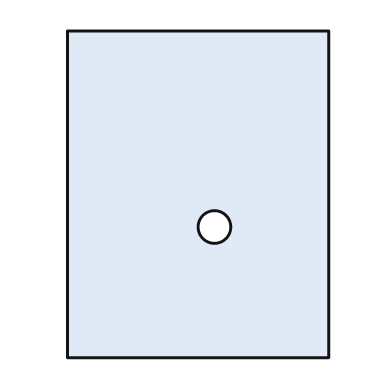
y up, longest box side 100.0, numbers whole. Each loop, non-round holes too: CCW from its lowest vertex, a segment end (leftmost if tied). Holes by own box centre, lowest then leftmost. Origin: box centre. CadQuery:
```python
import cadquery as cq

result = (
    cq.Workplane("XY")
    .moveTo(-40.0, -50.0)
    .lineTo(40.0, -50.0)
    .lineTo(40.0, 50.0)
    .lineTo(-40.0, 50.0)
    .close()
    .moveTo(5.0, -10.0)
    .circle(5.0)
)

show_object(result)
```